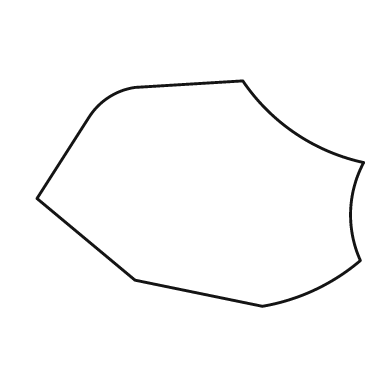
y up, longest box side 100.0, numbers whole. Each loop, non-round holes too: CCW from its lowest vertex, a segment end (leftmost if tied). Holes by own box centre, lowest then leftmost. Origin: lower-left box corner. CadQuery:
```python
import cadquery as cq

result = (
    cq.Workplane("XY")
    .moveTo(69.0, 0.0)
    .threePointArc((85.0, 5.0), (99.0, 14.0))
    .threePointArc((96.0, 29.0), (100.0, 44.0))
    .threePointArc((79.0, 53.0), (63.0, 69.0))
    .lineTo(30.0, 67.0)
    .threePointArc((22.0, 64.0), (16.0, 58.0))
    .lineTo(0.0, 33.0)
    .lineTo(30.0, 8.0)
    .close()
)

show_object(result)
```